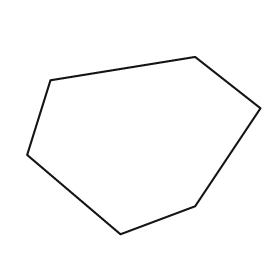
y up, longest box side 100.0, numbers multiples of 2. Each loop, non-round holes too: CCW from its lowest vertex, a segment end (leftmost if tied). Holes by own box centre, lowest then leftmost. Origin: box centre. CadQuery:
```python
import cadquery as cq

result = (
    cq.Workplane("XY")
    .moveTo(-10.0, -38.0)
    .lineTo(22.0, -26.0)
    .lineTo(50.0, 16.0)
    .lineTo(22.0, 38.0)
    .lineTo(-40.0, 28.0)
    .lineTo(-50.0, -4.0)
    .close()
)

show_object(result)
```